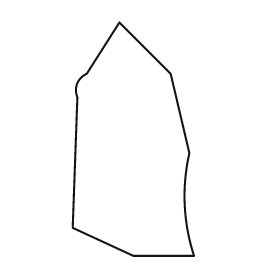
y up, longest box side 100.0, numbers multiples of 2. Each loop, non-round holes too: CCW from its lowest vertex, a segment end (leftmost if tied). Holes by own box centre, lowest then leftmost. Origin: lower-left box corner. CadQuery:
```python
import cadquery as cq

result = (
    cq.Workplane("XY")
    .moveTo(26.0, 0.0)
    .lineTo(52.0, 0.0)
    .threePointArc((48.0, 22.0), (50.0, 44.0))
    .lineTo(42.0, 78.0)
    .lineTo(20.0, 100.0)
    .lineTo(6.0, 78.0)
    .threePointArc((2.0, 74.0), (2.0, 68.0))
    .lineTo(0.0, 12.0)
    .close()
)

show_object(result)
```